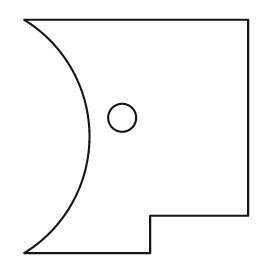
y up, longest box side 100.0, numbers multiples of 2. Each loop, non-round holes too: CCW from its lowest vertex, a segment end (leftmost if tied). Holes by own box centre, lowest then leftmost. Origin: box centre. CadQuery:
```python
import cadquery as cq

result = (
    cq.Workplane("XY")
    .moveTo(-48.0, -50.0)
    .lineTo(6.0, -50.0)
    .lineTo(6.0, -34.0)
    .lineTo(48.0, -34.0)
    .lineTo(48.0, 50.0)
    .lineTo(-48.0, 50.0)
    .threePointArc((-20.0, 0.0), (-48.0, -50.0))
    .close()
    .moveTo(-6.0, 8.0)
    .circle(6.0)
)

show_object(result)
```